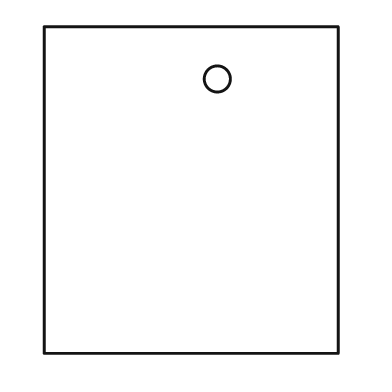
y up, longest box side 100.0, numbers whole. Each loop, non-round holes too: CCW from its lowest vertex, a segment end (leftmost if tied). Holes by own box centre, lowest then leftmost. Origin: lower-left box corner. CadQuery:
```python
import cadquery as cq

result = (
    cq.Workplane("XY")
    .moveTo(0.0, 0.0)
    .lineTo(90.0, 0.0)
    .lineTo(90.0, 100.0)
    .lineTo(0.0, 100.0)
    .close()
    .moveTo(53.0, 84.0)
    .circle(4.0)
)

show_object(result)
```